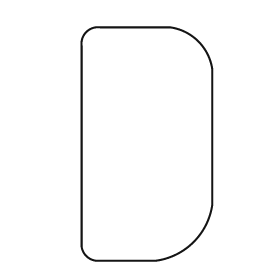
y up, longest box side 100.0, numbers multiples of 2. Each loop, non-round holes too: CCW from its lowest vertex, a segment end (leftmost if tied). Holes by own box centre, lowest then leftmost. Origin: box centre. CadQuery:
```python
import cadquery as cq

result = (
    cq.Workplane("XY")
    .moveTo(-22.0, -50.0)
    .lineTo(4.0, -50.0)
    .threePointArc((20.0, -42.0), (28.0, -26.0))
    .lineTo(28.0, 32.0)
    .threePointArc((22.0, 44.0), (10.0, 50.0))
    .lineTo(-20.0, 50.0)
    .threePointArc((-26.0, 48.0), (-28.0, 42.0))
    .lineTo(-28.0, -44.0)
    .threePointArc((-26.0, -48.0), (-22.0, -50.0))
    .close()
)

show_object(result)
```